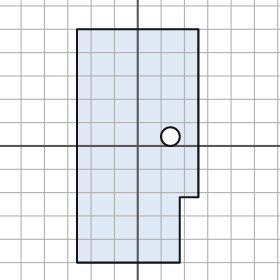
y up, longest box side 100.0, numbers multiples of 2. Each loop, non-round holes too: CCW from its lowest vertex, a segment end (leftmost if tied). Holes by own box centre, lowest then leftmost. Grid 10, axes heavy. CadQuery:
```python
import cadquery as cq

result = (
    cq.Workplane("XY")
    .moveTo(-26.0, -50.0)
    .lineTo(18.0, -50.0)
    .lineTo(18.0, -22.0)
    .lineTo(26.0, -22.0)
    .lineTo(26.0, 50.0)
    .lineTo(-26.0, 50.0)
    .close()
    .moveTo(14.0, 4.0)
    .circle(4.0)
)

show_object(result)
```